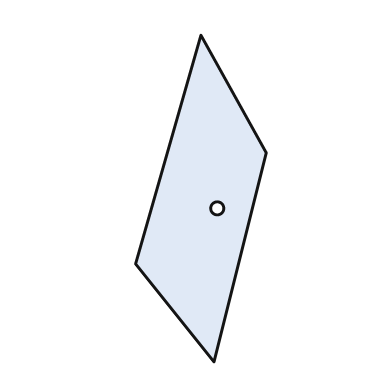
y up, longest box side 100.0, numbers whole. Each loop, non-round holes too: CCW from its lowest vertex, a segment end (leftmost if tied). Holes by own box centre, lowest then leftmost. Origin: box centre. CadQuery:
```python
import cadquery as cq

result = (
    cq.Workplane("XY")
    .moveTo(4.0, -50.0)
    .lineTo(20.0, 14.0)
    .lineTo(0.0, 50.0)
    .lineTo(-20.0, -20.0)
    .close()
    .moveTo(5.0, -3.0)
    .circle(2.0)
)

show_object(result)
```